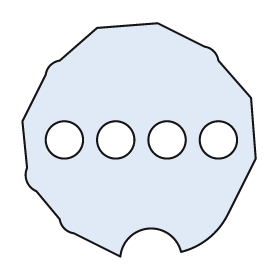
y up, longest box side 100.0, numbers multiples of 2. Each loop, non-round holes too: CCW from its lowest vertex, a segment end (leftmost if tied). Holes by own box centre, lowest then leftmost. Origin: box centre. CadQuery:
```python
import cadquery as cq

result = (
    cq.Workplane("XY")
    .moveTo(-8.0, -50.0)
    .threePointArc((4.0, -38.0), (18.0, -48.0))
    .threePointArc((30.0, -42.0), (38.0, -32.0))
    .lineTo(50.0, -8.0)
    .lineTo(48.0, 18.0)
    .lineTo(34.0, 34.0)
    .threePointArc((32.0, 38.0), (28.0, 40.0))
    .lineTo(8.0, 50.0)
    .lineTo(-18.0, 48.0)
    .lineTo(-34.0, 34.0)
    .threePointArc((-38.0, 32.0), (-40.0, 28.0))
    .lineTo(-50.0, 8.0)
    .lineTo(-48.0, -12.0)
    .threePointArc((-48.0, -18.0), (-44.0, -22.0))
    .lineTo(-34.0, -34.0)
    .threePointArc((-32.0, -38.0), (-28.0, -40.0))
    .close()
    .moveTo(-32.0, 0.0)
    .circle(8.0)
    .moveTo(-10.0, 0.0)
    .circle(8.0)
    .moveTo(12.0, 0.0)
    .circle(8.0)
    .moveTo(34.0, 0.0)
    .circle(8.0)
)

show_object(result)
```